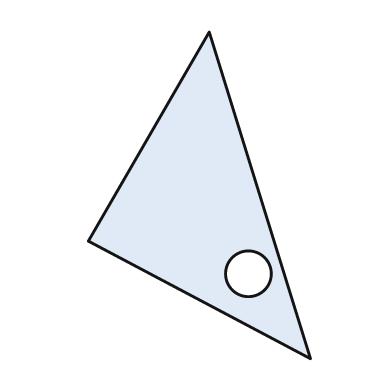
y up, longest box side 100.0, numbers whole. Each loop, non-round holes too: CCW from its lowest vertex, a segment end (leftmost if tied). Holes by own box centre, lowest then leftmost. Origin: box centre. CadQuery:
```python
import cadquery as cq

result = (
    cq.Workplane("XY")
    .moveTo(34.0, -50.0)
    .lineTo(3.0, 50.0)
    .lineTo(-34.0, -14.0)
    .close()
    .moveTo(15.0, -24.0)
    .circle(7.0)
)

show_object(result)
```